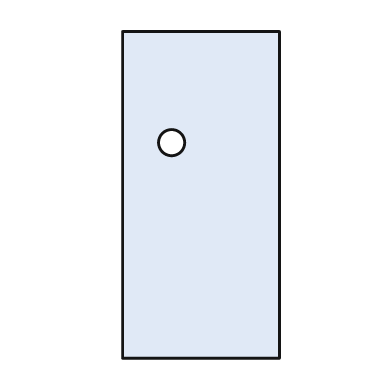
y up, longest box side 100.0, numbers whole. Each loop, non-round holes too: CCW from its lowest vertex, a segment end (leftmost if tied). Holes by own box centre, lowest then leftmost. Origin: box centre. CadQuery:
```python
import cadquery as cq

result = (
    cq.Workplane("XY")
    .moveTo(-24.0, -50.0)
    .lineTo(24.0, -50.0)
    .lineTo(24.0, 50.0)
    .lineTo(-24.0, 50.0)
    .close()
    .moveTo(-9.0, 16.0)
    .circle(4.0)
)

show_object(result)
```